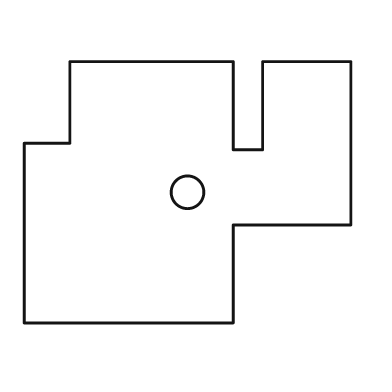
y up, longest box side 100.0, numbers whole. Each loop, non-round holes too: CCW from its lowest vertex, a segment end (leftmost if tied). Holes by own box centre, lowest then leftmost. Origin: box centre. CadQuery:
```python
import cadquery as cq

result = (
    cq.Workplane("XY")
    .moveTo(-50.0, -40.0)
    .lineTo(14.0, -40.0)
    .lineTo(14.0, -10.0)
    .lineTo(50.0, -10.0)
    .lineTo(50.0, 40.0)
    .lineTo(23.0, 40.0)
    .lineTo(23.0, 13.0)
    .lineTo(14.0, 13.0)
    .lineTo(14.0, 40.0)
    .lineTo(-36.0, 40.0)
    .lineTo(-36.0, 15.0)
    .lineTo(-50.0, 15.0)
    .close()
    .moveTo(0.0, 0.0)
    .circle(5.0)
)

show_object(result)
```